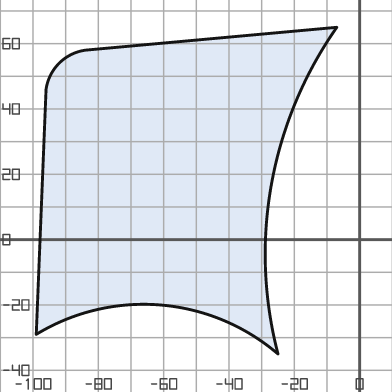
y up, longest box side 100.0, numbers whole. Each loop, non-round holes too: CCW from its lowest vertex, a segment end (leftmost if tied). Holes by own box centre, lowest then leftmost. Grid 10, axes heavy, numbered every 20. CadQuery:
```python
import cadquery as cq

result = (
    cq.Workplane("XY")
    .moveTo(-25.0, -35.0)
    .threePointArc((-27.0, 17.0), (-7.0, 65.0))
    .lineTo(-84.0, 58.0)
    .threePointArc((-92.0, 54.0), (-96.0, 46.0))
    .lineTo(-99.0, -29.0)
    .threePointArc((-61.0, -20.0), (-25.0, -35.0))
    .close()
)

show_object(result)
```